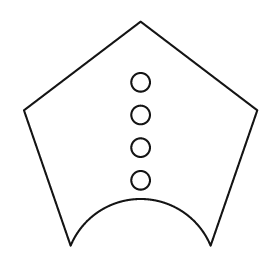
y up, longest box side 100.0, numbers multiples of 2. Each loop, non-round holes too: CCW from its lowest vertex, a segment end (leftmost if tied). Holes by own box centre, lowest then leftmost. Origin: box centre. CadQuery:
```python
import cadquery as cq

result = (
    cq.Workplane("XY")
    .moveTo(-30.0, -48.0)
    .threePointArc((0.0, -28.0), (30.0, -48.0))
    .lineTo(50.0, 10.0)
    .lineTo(0.0, 48.0)
    .lineTo(-50.0, 10.0)
    .close()
    .moveTo(0.0, -20.0)
    .circle(4.0)
    .moveTo(0.0, -6.0)
    .circle(4.0)
    .moveTo(0.0, 8.0)
    .circle(4.0)
    .moveTo(0.0, 22.0)
    .circle(4.0)
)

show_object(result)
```